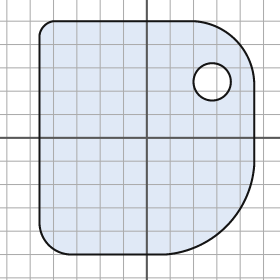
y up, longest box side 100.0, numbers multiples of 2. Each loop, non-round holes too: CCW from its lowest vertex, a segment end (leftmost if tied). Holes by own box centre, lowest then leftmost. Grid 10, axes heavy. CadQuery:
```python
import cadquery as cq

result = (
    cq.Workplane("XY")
    .moveTo(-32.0, -50.0)
    .lineTo(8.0, -50.0)
    .threePointArc((34.0, -38.0), (46.0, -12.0))
    .lineTo(46.0, 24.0)
    .threePointArc((38.0, 42.0), (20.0, 50.0))
    .lineTo(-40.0, 50.0)
    .threePointArc((-44.0, 48.0), (-46.0, 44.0))
    .lineTo(-46.0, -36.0)
    .threePointArc((-42.0, -46.0), (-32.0, -50.0))
    .close()
    .moveTo(28.0, 24.0)
    .circle(8.0)
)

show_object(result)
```